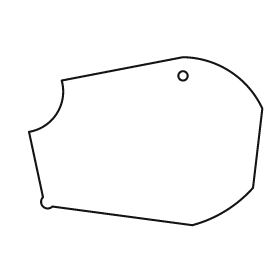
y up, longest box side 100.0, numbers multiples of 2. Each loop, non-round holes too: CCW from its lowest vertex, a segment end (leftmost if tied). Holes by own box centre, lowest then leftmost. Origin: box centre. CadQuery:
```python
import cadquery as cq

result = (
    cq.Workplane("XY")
    .moveTo(20.0, -36.0)
    .threePointArc((34.0, -30.0), (46.0, -20.0))
    .lineTo(50.0, 14.0)
    .threePointArc((36.0, 30.0), (16.0, 36.0))
    .lineTo(-36.0, 26.0)
    .threePointArc((-38.0, 12.0), (-50.0, 4.0))
    .lineTo(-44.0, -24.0)
    .threePointArc((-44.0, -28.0), (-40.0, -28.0))
    .close()
    .moveTo(16.0, 28.0)
    .circle(2.0)
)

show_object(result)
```